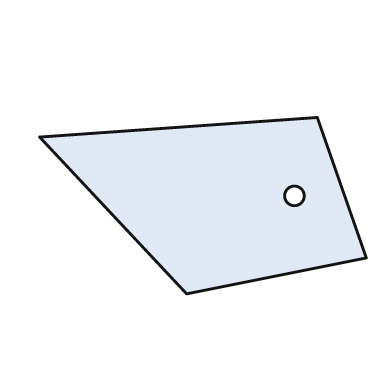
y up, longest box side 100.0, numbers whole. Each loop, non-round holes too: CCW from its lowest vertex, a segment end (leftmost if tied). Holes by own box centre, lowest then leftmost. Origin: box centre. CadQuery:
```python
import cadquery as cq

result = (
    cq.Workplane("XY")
    .moveTo(-5.0, -27.0)
    .lineTo(50.0, -16.0)
    .lineTo(35.0, 27.0)
    .lineTo(-50.0, 21.0)
    .close()
    .moveTo(28.0, 3.0)
    .circle(3.0)
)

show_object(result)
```